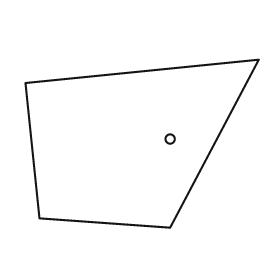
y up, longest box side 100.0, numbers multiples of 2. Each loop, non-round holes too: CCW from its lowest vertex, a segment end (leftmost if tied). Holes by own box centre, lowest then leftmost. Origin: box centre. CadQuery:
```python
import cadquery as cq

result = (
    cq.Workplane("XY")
    .moveTo(12.0, -36.0)
    .lineTo(50.0, 36.0)
    .lineTo(-50.0, 26.0)
    .lineTo(-44.0, -32.0)
    .close()
    .moveTo(12.0, 2.0)
    .circle(2.0)
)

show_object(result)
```